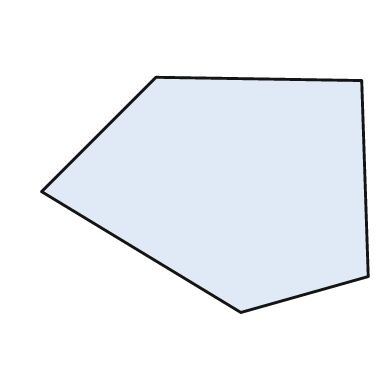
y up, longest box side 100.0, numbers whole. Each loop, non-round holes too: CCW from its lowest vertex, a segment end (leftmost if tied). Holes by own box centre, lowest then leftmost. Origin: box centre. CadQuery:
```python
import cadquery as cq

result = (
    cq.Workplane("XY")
    .moveTo(11.0, -36.0)
    .lineTo(50.0, -25.0)
    .lineTo(48.0, 35.0)
    .lineTo(-15.0, 36.0)
    .lineTo(-50.0, 1.0)
    .close()
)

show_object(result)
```